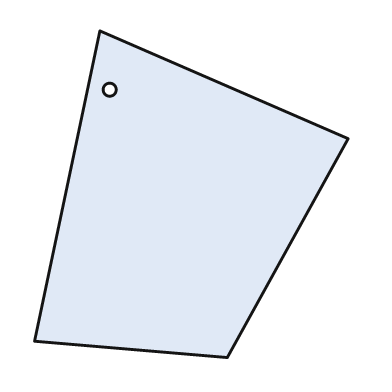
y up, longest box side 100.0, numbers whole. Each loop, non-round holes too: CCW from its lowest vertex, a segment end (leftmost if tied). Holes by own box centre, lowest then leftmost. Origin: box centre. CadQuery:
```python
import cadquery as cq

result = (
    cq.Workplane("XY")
    .moveTo(11.0, -50.0)
    .lineTo(48.0, 17.0)
    .lineTo(-28.0, 50.0)
    .lineTo(-48.0, -45.0)
    .close()
    .moveTo(-25.0, 32.0)
    .circle(2.0)
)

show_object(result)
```